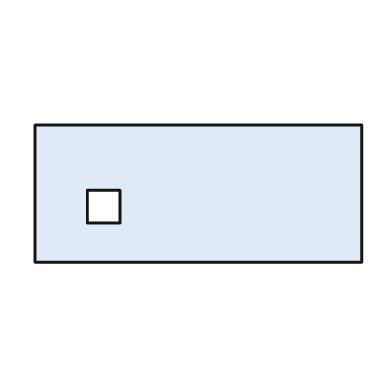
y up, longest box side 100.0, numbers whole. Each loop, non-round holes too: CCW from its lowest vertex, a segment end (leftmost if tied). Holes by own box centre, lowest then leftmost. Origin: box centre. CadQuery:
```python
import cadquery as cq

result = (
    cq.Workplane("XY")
    .moveTo(-50.0, -21.0)
    .lineTo(50.0, -21.0)
    .lineTo(50.0, 21.0)
    .lineTo(-50.0, 21.0)
    .close()
    .moveTo(-34.0, -9.0)
    .lineTo(-24.0, -9.0)
    .lineTo(-24.0, 1.0)
    .lineTo(-34.0, 1.0)
    .close()
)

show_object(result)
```